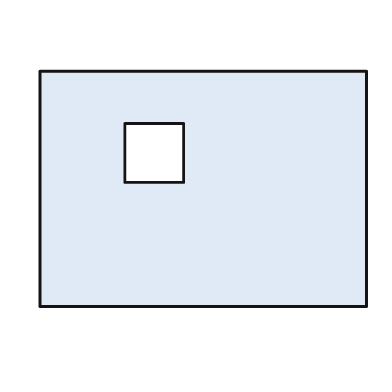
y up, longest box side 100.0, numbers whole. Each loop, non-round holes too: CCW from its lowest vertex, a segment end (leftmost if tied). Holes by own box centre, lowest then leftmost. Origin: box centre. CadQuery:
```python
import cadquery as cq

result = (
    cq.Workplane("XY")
    .moveTo(-50.0, -36.0)
    .lineTo(50.0, -36.0)
    .lineTo(50.0, 36.0)
    .lineTo(-50.0, 36.0)
    .close()
    .moveTo(-24.0, 2.0)
    .lineTo(-6.0, 2.0)
    .lineTo(-6.0, 20.0)
    .lineTo(-24.0, 20.0)
    .close()
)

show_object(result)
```